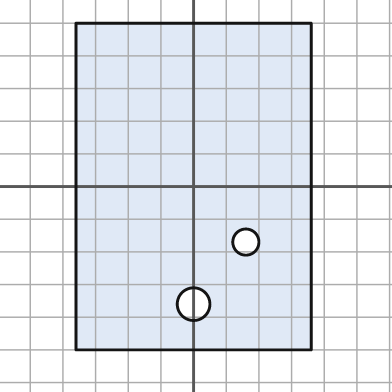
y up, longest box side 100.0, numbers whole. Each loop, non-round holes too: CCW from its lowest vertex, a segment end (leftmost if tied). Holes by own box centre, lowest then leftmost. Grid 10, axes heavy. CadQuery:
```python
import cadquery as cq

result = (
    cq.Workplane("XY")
    .moveTo(-36.0, -50.0)
    .lineTo(36.0, -50.0)
    .lineTo(36.0, 50.0)
    .lineTo(-36.0, 50.0)
    .close()
    .moveTo(0.0, -36.0)
    .circle(5.0)
    .moveTo(16.0, -17.0)
    .circle(4.0)
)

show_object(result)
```